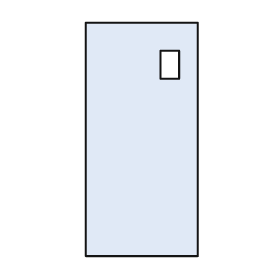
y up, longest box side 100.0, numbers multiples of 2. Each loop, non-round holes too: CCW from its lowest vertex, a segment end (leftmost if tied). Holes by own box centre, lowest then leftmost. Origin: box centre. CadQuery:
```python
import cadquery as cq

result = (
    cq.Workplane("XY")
    .moveTo(-24.0, -50.0)
    .lineTo(24.0, -50.0)
    .lineTo(24.0, 50.0)
    .lineTo(-24.0, 50.0)
    .close()
    .moveTo(8.0, 26.0)
    .lineTo(16.0, 26.0)
    .lineTo(16.0, 38.0)
    .lineTo(8.0, 38.0)
    .close()
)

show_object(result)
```